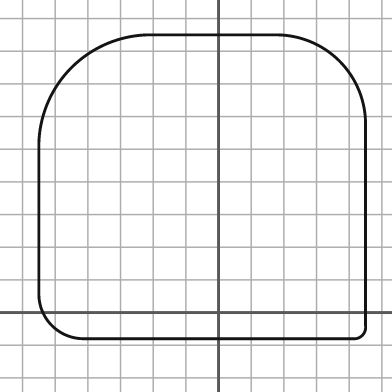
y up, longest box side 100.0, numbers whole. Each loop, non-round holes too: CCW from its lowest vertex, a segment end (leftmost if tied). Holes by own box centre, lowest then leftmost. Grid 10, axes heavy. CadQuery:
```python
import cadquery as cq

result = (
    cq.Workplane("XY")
    .moveTo(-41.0, -8.0)
    .lineTo(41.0, -8.0)
    .threePointArc((44.0, -7.0), (45.0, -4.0))
    .lineTo(45.0, 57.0)
    .threePointArc((37.0, 77.0), (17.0, 85.0))
    .lineTo(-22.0, 85.0)
    .threePointArc((-45.0, 75.0), (-55.0, 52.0))
    .lineTo(-55.0, 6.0)
    .threePointArc((-51.0, -4.0), (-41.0, -8.0))
    .close()
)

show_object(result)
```